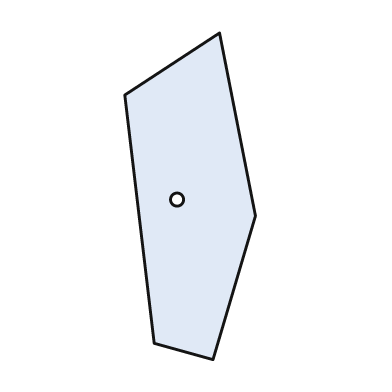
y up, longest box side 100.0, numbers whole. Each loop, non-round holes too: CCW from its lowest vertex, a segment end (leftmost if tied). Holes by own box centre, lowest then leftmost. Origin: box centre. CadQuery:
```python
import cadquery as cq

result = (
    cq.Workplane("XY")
    .moveTo(7.0, -50.0)
    .lineTo(20.0, -6.0)
    .lineTo(9.0, 50.0)
    .lineTo(-20.0, 31.0)
    .lineTo(-11.0, -45.0)
    .close()
    .moveTo(-4.0, -1.0)
    .circle(2.0)
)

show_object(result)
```